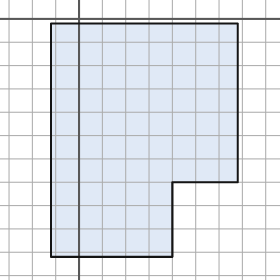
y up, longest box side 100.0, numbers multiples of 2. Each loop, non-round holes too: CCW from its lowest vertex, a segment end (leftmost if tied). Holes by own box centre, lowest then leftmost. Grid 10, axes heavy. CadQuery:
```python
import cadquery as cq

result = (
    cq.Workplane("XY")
    .moveTo(-12.0, -102.0)
    .lineTo(40.0, -102.0)
    .lineTo(40.0, -70.0)
    .lineTo(68.0, -70.0)
    .lineTo(68.0, -2.0)
    .lineTo(-12.0, -2.0)
    .close()
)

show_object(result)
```